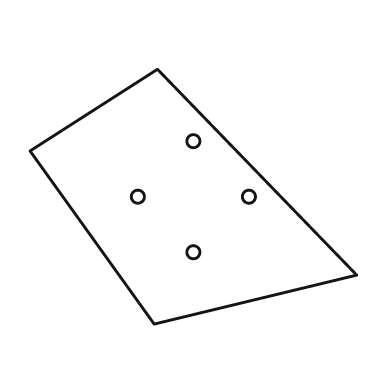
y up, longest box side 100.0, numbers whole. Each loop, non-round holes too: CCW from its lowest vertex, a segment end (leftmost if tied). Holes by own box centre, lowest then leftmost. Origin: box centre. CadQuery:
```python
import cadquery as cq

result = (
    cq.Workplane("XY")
    .moveTo(-12.0, -39.0)
    .lineTo(50.0, -24.0)
    .lineTo(-11.0, 39.0)
    .lineTo(-50.0, 14.0)
    .close()
    .moveTo(0.0, -17.0)
    .circle(2.0)
    .moveTo(-17.0, 0.0)
    .circle(2.0)
    .moveTo(17.0, 0.0)
    .circle(2.0)
    .moveTo(0.0, 17.0)
    .circle(2.0)
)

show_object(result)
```